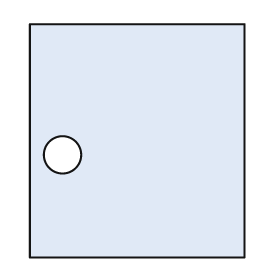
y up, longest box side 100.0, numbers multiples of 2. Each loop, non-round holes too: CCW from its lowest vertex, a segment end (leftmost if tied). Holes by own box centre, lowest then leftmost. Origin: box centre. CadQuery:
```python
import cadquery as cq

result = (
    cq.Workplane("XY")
    .moveTo(-46.0, -50.0)
    .lineTo(46.0, -50.0)
    .lineTo(46.0, 50.0)
    .lineTo(-46.0, 50.0)
    .close()
    .moveTo(-32.0, -6.0)
    .circle(8.0)
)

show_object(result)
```